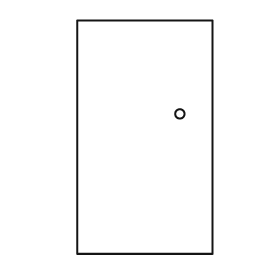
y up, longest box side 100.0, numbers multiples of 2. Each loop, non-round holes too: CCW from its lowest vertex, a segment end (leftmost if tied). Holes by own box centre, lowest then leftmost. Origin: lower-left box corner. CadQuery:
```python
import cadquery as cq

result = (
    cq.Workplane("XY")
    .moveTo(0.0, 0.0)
    .lineTo(58.0, 0.0)
    .lineTo(58.0, 100.0)
    .lineTo(0.0, 100.0)
    .close()
    .moveTo(44.0, 60.0)
    .circle(2.0)
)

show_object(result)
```